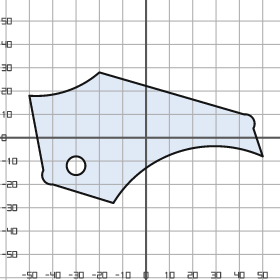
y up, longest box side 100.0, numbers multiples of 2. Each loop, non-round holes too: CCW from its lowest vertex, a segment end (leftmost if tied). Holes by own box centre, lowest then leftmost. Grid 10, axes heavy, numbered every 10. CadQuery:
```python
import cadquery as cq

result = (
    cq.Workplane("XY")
    .moveTo(-14.0, -28.0)
    .threePointArc((14.0, -6.0), (50.0, -8.0))
    .lineTo(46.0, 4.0)
    .threePointArc((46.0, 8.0), (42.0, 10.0))
    .lineTo(-20.0, 28.0)
    .threePointArc((-34.0, 20.0), (-50.0, 18.0))
    .lineTo(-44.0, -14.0)
    .threePointArc((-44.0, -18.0), (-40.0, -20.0))
    .close()
    .moveTo(-30.0, -12.0)
    .circle(4.0)
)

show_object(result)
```